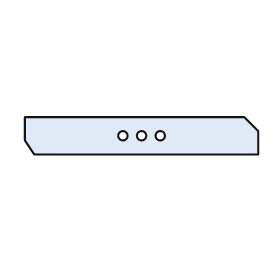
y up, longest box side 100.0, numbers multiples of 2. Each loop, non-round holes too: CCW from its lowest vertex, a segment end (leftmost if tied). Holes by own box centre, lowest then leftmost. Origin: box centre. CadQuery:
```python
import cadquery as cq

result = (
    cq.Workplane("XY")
    .moveTo(-46.0, -8.0)
    .lineTo(50.0, -8.0)
    .lineTo(50.0, 2.0)
    .lineTo(44.0, 8.0)
    .lineTo(-50.0, 8.0)
    .lineTo(-50.0, -2.0)
    .close()
    .moveTo(-8.0, 0.0)
    .circle(2.0)
    .moveTo(0.0, 0.0)
    .circle(2.0)
    .moveTo(8.0, 0.0)
    .circle(2.0)
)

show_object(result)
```